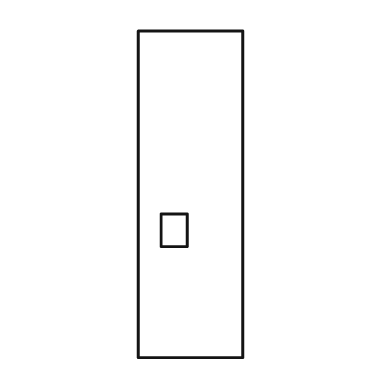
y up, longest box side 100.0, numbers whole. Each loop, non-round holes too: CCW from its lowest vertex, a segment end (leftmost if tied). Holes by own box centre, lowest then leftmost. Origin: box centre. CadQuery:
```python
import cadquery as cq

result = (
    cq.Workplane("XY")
    .moveTo(-16.0, -50.0)
    .lineTo(16.0, -50.0)
    .lineTo(16.0, 50.0)
    .lineTo(-16.0, 50.0)
    .close()
    .moveTo(-9.0, -16.0)
    .lineTo(-1.0, -16.0)
    .lineTo(-1.0, -6.0)
    .lineTo(-9.0, -6.0)
    .close()
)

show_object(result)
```